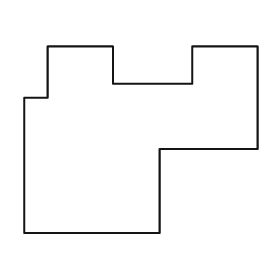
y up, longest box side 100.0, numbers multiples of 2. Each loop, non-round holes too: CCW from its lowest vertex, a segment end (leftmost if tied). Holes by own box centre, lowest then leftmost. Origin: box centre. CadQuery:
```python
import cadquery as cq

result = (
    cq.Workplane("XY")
    .moveTo(-50.0, -40.0)
    .lineTo(8.0, -40.0)
    .lineTo(8.0, -4.0)
    .lineTo(50.0, -4.0)
    .lineTo(50.0, 40.0)
    .lineTo(22.0, 40.0)
    .lineTo(22.0, 24.0)
    .lineTo(-12.0, 24.0)
    .lineTo(-12.0, 40.0)
    .lineTo(-40.0, 40.0)
    .lineTo(-40.0, 18.0)
    .lineTo(-50.0, 18.0)
    .close()
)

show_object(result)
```